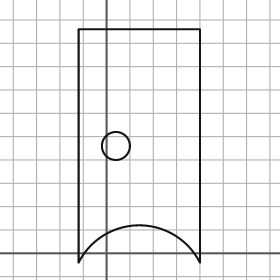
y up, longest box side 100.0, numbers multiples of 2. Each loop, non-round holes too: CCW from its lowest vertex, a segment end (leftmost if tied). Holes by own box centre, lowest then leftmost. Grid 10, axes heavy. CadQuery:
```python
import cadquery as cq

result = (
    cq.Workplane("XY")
    .moveTo(-12.0, -4.0)
    .threePointArc((14.0, 12.0), (40.0, -4.0))
    .lineTo(40.0, 96.0)
    .lineTo(-12.0, 96.0)
    .close()
    .moveTo(4.0, 46.0)
    .circle(6.0)
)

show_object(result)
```